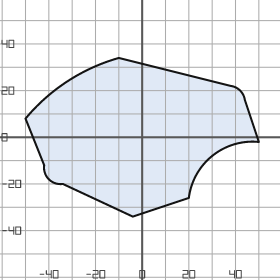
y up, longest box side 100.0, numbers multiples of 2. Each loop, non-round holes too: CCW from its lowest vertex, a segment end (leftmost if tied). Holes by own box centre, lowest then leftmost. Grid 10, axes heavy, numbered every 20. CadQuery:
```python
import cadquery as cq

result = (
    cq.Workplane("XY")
    .moveTo(-4.0, -34.0)
    .lineTo(20.0, -26.0)
    .threePointArc((30.0, -8.0), (50.0, -2.0))
    .lineTo(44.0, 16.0)
    .threePointArc((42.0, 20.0), (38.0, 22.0))
    .lineTo(-10.0, 34.0)
    .threePointArc((-32.0, 24.0), (-50.0, 8.0))
    .lineTo(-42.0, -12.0)
    .threePointArc((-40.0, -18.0), (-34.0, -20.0))
    .close()
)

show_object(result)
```